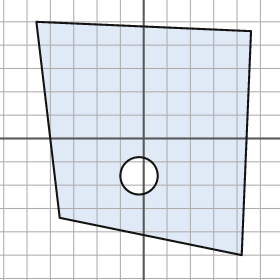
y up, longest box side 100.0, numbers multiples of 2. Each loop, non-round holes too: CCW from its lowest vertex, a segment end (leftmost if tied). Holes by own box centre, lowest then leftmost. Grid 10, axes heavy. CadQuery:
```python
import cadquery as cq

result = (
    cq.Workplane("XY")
    .moveTo(42.0, -50.0)
    .lineTo(46.0, 46.0)
    .lineTo(-46.0, 50.0)
    .lineTo(-36.0, -34.0)
    .close()
    .moveTo(-2.0, -16.0)
    .circle(8.0)
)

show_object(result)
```